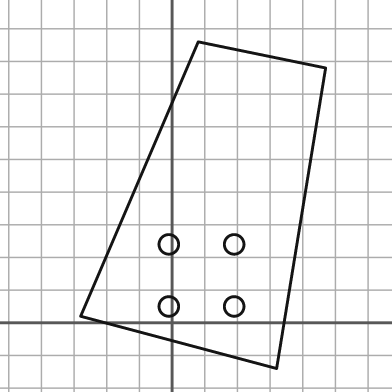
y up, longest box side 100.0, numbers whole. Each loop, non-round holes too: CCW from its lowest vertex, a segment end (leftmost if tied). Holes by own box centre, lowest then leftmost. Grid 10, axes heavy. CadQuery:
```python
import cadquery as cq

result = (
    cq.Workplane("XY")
    .moveTo(32.0, -14.0)
    .lineTo(47.0, 78.0)
    .lineTo(8.0, 86.0)
    .lineTo(-28.0, 2.0)
    .close()
    .moveTo(-1.0, 5.0)
    .circle(3.0)
    .moveTo(19.0, 5.0)
    .circle(3.0)
    .moveTo(-1.0, 24.0)
    .circle(3.0)
    .moveTo(19.0, 24.0)
    .circle(3.0)
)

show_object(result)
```